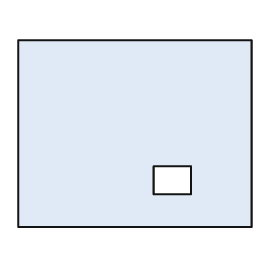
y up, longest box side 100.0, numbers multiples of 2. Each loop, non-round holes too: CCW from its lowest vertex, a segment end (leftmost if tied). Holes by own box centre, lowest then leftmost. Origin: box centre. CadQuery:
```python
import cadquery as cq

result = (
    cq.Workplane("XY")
    .moveTo(-50.0, -40.0)
    .lineTo(50.0, -40.0)
    .lineTo(50.0, 40.0)
    .lineTo(-50.0, 40.0)
    .close()
    .moveTo(8.0, -26.0)
    .lineTo(24.0, -26.0)
    .lineTo(24.0, -14.0)
    .lineTo(8.0, -14.0)
    .close()
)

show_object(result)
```